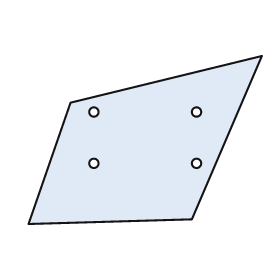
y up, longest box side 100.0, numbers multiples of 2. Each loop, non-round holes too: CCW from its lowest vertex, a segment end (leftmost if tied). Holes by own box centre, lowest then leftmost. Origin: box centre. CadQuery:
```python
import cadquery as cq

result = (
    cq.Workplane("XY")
    .moveTo(-50.0, -36.0)
    .lineTo(20.0, -34.0)
    .lineTo(50.0, 36.0)
    .lineTo(-32.0, 16.0)
    .close()
    .moveTo(-22.0, -10.0)
    .circle(2.0)
    .moveTo(22.0, -10.0)
    .circle(2.0)
    .moveTo(-22.0, 12.0)
    .circle(2.0)
    .moveTo(22.0, 12.0)
    .circle(2.0)
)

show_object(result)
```